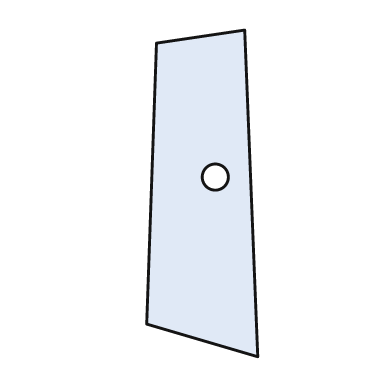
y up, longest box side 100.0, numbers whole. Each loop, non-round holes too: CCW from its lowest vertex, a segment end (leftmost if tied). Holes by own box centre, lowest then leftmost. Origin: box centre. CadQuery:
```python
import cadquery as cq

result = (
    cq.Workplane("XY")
    .moveTo(17.0, -50.0)
    .lineTo(13.0, 50.0)
    .lineTo(-14.0, 46.0)
    .lineTo(-17.0, -40.0)
    .close()
    .moveTo(4.0, 5.0)
    .circle(4.0)
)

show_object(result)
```